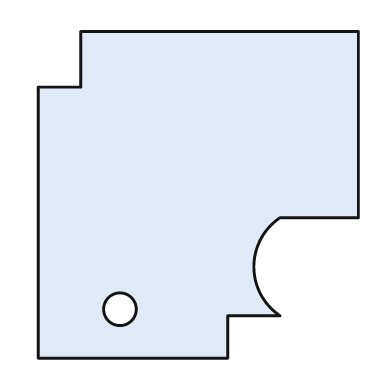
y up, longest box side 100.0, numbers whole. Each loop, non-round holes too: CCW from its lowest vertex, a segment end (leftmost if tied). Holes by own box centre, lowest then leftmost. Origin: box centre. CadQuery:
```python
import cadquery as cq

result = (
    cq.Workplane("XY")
    .moveTo(-49.0, -50.0)
    .lineTo(9.0, -50.0)
    .lineTo(9.0, -37.0)
    .lineTo(25.0, -37.0)
    .threePointArc((17.0, -22.0), (25.0, -7.0))
    .lineTo(49.0, -7.0)
    .lineTo(49.0, 50.0)
    .lineTo(-36.0, 50.0)
    .lineTo(-36.0, 33.0)
    .lineTo(-49.0, 33.0)
    .close()
    .moveTo(-24.0, -35.0)
    .circle(5.0)
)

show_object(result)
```